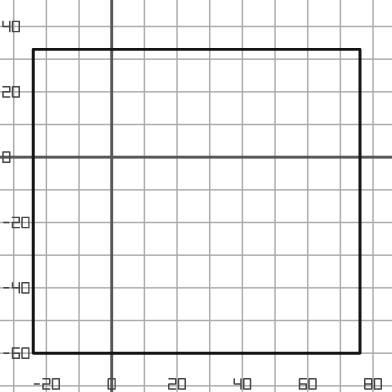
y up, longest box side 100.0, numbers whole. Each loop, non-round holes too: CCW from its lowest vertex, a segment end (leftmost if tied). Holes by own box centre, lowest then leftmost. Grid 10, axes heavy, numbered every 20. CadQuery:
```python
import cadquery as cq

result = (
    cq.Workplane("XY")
    .moveTo(-24.0, -60.0)
    .lineTo(76.0, -60.0)
    .lineTo(76.0, 33.0)
    .lineTo(-24.0, 33.0)
    .close()
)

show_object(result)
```